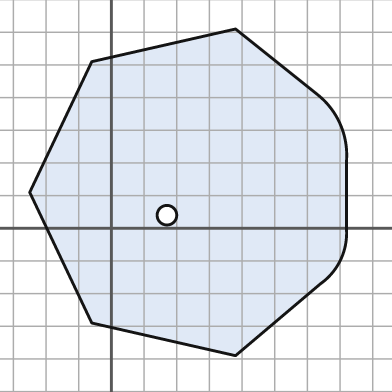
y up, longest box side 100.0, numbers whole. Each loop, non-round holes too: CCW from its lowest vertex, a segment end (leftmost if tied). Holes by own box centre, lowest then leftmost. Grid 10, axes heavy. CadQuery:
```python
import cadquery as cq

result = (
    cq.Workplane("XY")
    .moveTo(38.0, -39.0)
    .lineTo(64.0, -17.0)
    .threePointArc((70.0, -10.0), (72.0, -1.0))
    .lineTo(72.0, 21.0)
    .threePointArc((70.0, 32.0), (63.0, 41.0))
    .lineTo(38.0, 61.0)
    .lineTo(-6.0, 51.0)
    .lineTo(-25.0, 11.0)
    .lineTo(-6.0, -29.0)
    .close()
    .moveTo(17.0, 4.0)
    .circle(3.0)
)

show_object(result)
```